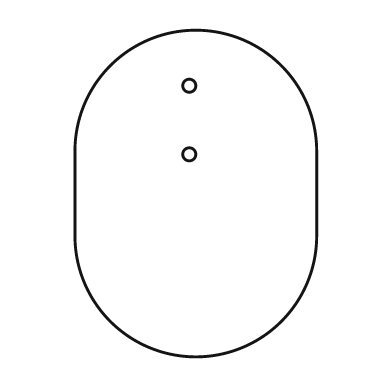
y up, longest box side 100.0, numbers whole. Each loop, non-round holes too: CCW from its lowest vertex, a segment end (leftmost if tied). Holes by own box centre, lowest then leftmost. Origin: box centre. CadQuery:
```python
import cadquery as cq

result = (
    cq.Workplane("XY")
    .moveTo(-37.0, -13.0)
    .threePointArc((0.0, -50.0), (37.0, -13.0))
    .lineTo(37.0, 13.0)
    .threePointArc((0.0, 50.0), (-37.0, 13.0))
    .close()
    .moveTo(-2.0, 12.0)
    .circle(2.0)
    .moveTo(-2.0, 33.0)
    .circle(2.0)
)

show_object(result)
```